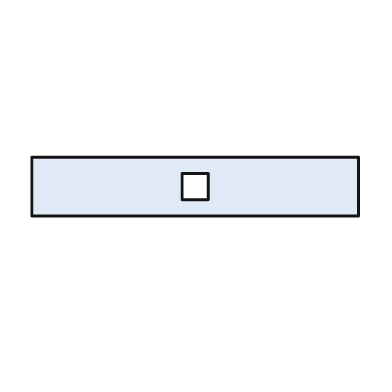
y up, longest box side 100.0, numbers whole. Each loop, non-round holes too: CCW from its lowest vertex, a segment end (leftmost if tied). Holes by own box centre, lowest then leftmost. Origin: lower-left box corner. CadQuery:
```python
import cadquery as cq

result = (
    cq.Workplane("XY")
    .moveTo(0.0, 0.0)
    .lineTo(100.0, 0.0)
    .lineTo(100.0, 18.0)
    .lineTo(0.0, 18.0)
    .close()
    .moveTo(46.0, 5.0)
    .lineTo(54.0, 5.0)
    .lineTo(54.0, 13.0)
    .lineTo(46.0, 13.0)
    .close()
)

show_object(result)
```